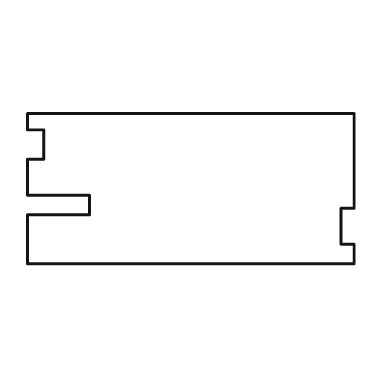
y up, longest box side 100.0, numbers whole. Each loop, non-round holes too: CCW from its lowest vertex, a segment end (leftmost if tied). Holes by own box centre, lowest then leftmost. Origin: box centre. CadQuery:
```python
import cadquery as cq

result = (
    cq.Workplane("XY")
    .moveTo(-50.0, -23.0)
    .lineTo(50.0, -23.0)
    .lineTo(50.0, -17.0)
    .lineTo(46.0, -17.0)
    .lineTo(46.0, -6.0)
    .lineTo(50.0, -6.0)
    .lineTo(50.0, 23.0)
    .lineTo(-50.0, 23.0)
    .lineTo(-50.0, 18.0)
    .lineTo(-45.0, 18.0)
    .lineTo(-45.0, 9.0)
    .lineTo(-50.0, 9.0)
    .lineTo(-50.0, -2.0)
    .lineTo(-31.0, -2.0)
    .lineTo(-31.0, -8.0)
    .lineTo(-50.0, -8.0)
    .close()
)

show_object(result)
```